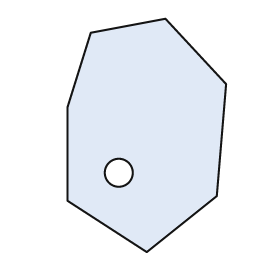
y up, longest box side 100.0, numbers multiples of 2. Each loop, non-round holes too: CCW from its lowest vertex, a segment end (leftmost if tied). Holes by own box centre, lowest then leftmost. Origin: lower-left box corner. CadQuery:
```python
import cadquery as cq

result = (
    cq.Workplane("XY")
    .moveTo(34.0, 0.0)
    .lineTo(64.0, 24.0)
    .lineTo(68.0, 72.0)
    .lineTo(42.0, 100.0)
    .lineTo(10.0, 94.0)
    .lineTo(0.0, 62.0)
    .lineTo(0.0, 22.0)
    .close()
    .moveTo(22.0, 34.0)
    .circle(6.0)
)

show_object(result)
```